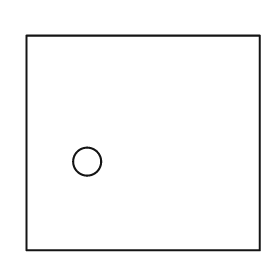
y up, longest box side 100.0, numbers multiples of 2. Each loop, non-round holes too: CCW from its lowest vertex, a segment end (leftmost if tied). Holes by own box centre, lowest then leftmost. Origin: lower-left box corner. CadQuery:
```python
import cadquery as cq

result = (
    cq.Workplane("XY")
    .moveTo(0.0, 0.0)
    .lineTo(100.0, 0.0)
    .lineTo(100.0, 92.0)
    .lineTo(0.0, 92.0)
    .close()
    .moveTo(26.0, 38.0)
    .circle(6.0)
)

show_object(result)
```